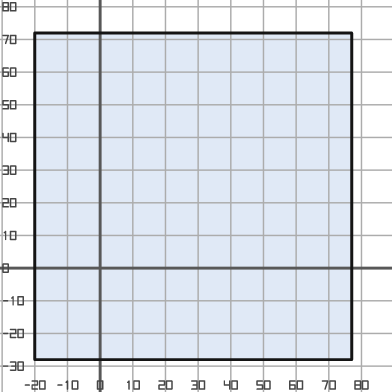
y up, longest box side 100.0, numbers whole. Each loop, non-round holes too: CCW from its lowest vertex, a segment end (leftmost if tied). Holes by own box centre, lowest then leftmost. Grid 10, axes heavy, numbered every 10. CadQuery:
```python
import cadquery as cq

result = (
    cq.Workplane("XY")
    .moveTo(-20.0, -28.0)
    .lineTo(77.0, -28.0)
    .lineTo(77.0, 72.0)
    .lineTo(-20.0, 72.0)
    .close()
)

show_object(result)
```